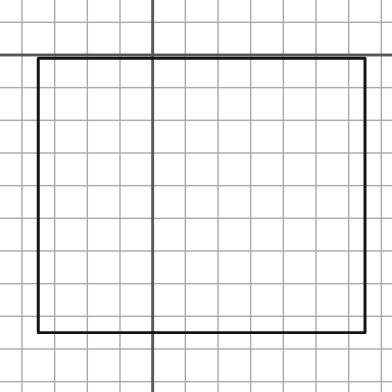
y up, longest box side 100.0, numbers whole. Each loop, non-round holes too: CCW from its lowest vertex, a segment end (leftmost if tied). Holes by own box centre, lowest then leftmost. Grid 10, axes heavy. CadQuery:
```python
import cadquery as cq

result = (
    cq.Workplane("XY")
    .moveTo(-35.0, -85.0)
    .lineTo(65.0, -85.0)
    .lineTo(65.0, -1.0)
    .lineTo(-35.0, -1.0)
    .close()
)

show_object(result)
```